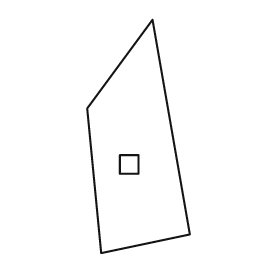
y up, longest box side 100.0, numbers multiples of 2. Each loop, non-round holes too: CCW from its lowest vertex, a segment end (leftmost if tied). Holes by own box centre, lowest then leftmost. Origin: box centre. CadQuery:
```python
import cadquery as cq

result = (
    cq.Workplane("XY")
    .moveTo(-16.0, -50.0)
    .lineTo(22.0, -42.0)
    .lineTo(6.0, 50.0)
    .lineTo(-22.0, 12.0)
    .close()
    .moveTo(-8.0, -16.0)
    .lineTo(0.0, -16.0)
    .lineTo(0.0, -8.0)
    .lineTo(-8.0, -8.0)
    .close()
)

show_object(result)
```